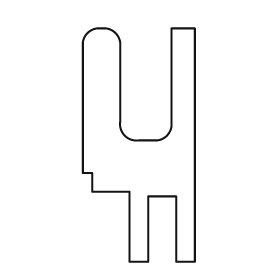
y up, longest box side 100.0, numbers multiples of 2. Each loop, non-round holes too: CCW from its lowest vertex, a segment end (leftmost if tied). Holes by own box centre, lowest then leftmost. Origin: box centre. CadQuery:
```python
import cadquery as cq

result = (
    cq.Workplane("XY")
    .moveTo(-4.0, -50.0)
    .lineTo(4.0, -50.0)
    .lineTo(4.0, -22.0)
    .lineTo(16.0, -22.0)
    .lineTo(16.0, -50.0)
    .lineTo(24.0, -50.0)
    .lineTo(24.0, 50.0)
    .lineTo(14.0, 50.0)
    .lineTo(14.0, 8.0)
    .threePointArc((12.0, 4.0), (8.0, 2.0))
    .lineTo(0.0, 2.0)
    .threePointArc((-6.0, 4.0), (-8.0, 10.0))
    .lineTo(-8.0, 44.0)
    .threePointArc((-10.0, 48.0), (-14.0, 50.0))
    .lineTo(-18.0, 50.0)
    .threePointArc((-22.0, 48.0), (-24.0, 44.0))
    .lineTo(-24.0, -12.0)
    .lineTo(-20.0, -12.0)
    .lineTo(-20.0, -20.0)
    .lineTo(-4.0, -20.0)
    .close()
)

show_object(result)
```